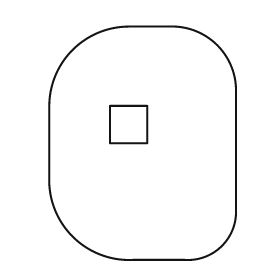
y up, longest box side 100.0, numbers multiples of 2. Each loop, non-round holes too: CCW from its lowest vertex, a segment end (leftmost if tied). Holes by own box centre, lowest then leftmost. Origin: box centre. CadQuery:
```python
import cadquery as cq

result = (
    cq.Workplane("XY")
    .moveTo(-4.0, -50.0)
    .lineTo(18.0, -50.0)
    .threePointArc((34.0, -44.0), (40.0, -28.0))
    .lineTo(40.0, 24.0)
    .threePointArc((32.0, 42.0), (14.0, 50.0))
    .lineTo(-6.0, 50.0)
    .threePointArc((-30.0, 40.0), (-40.0, 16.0))
    .lineTo(-40.0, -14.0)
    .threePointArc((-30.0, -40.0), (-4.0, -50.0))
    .close()
    .moveTo(-14.0, 0.0)
    .lineTo(2.0, 0.0)
    .lineTo(2.0, 16.0)
    .lineTo(-14.0, 16.0)
    .close()
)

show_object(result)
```